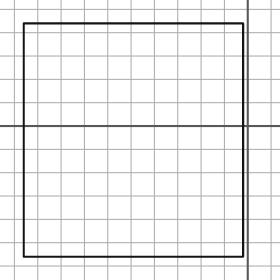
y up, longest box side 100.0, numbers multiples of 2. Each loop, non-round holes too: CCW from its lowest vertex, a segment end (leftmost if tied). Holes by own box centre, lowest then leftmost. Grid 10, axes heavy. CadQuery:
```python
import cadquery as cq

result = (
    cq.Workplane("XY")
    .moveTo(-96.0, -56.0)
    .lineTo(-2.0, -56.0)
    .lineTo(-2.0, 44.0)
    .lineTo(-96.0, 44.0)
    .close()
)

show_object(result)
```